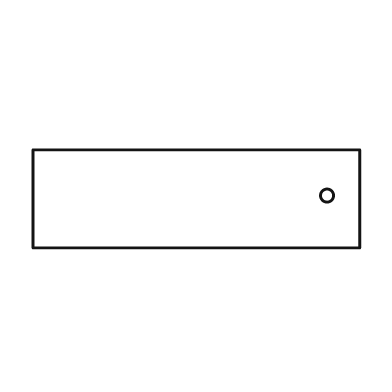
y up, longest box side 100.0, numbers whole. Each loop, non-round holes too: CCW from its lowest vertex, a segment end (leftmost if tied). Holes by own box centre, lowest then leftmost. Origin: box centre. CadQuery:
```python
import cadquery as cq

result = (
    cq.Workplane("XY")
    .moveTo(-50.0, -15.0)
    .lineTo(50.0, -15.0)
    .lineTo(50.0, 15.0)
    .lineTo(-50.0, 15.0)
    .close()
    .moveTo(40.0, 1.0)
    .circle(2.0)
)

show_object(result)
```